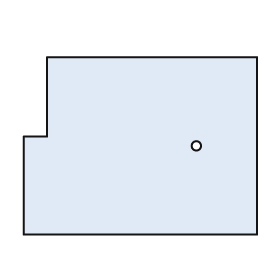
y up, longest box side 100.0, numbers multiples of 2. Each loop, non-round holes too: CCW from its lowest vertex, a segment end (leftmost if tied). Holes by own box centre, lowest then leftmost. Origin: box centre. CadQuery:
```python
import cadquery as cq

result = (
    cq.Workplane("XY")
    .moveTo(-50.0, -38.0)
    .lineTo(50.0, -38.0)
    .lineTo(50.0, 38.0)
    .lineTo(-40.0, 38.0)
    .lineTo(-40.0, 4.0)
    .lineTo(-50.0, 4.0)
    .close()
    .moveTo(24.0, 0.0)
    .circle(2.0)
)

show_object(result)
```